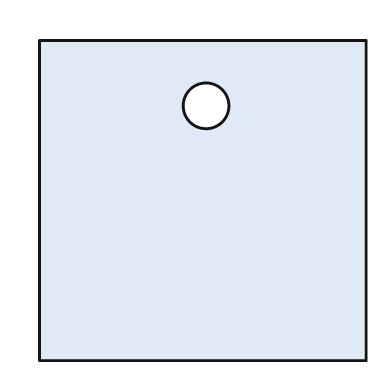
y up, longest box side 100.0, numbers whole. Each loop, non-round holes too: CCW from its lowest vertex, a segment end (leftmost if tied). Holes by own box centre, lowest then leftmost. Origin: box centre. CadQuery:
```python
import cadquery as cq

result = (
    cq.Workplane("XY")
    .moveTo(-50.0, -49.0)
    .lineTo(50.0, -49.0)
    .lineTo(50.0, 49.0)
    .lineTo(-50.0, 49.0)
    .close()
    .moveTo(1.0, 29.0)
    .circle(7.0)
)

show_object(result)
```